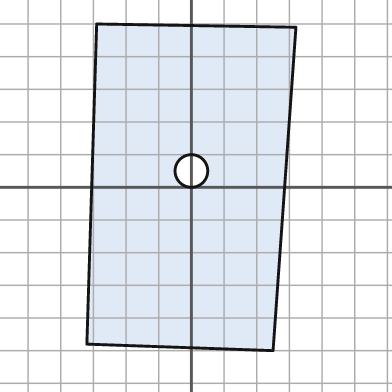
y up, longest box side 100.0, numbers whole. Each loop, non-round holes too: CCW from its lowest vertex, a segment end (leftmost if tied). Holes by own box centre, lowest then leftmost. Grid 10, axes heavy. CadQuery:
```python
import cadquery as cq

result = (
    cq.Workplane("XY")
    .moveTo(25.0, -50.0)
    .lineTo(32.0, 49.0)
    .lineTo(-29.0, 50.0)
    .lineTo(-32.0, -48.0)
    .close()
    .moveTo(0.0, 5.0)
    .circle(5.0)
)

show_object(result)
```